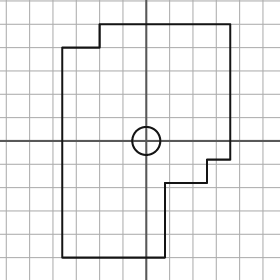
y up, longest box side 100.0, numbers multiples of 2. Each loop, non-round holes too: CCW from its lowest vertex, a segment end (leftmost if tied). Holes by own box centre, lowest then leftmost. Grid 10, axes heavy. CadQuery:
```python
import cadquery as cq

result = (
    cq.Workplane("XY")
    .moveTo(-36.0, -50.0)
    .lineTo(8.0, -50.0)
    .lineTo(8.0, -18.0)
    .lineTo(26.0, -18.0)
    .lineTo(26.0, -8.0)
    .lineTo(36.0, -8.0)
    .lineTo(36.0, 50.0)
    .lineTo(-20.0, 50.0)
    .lineTo(-20.0, 40.0)
    .lineTo(-36.0, 40.0)
    .close()
    .moveTo(0.0, 0.0)
    .circle(6.0)
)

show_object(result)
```